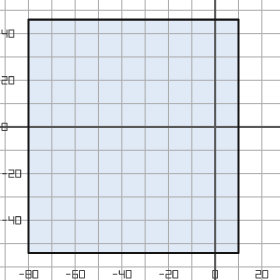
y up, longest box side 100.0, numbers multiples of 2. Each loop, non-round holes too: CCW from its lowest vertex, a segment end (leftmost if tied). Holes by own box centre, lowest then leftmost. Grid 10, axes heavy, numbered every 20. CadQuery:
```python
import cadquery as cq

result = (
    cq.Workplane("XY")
    .moveTo(-80.0, -54.0)
    .lineTo(10.0, -54.0)
    .lineTo(10.0, 46.0)
    .lineTo(-80.0, 46.0)
    .close()
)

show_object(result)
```